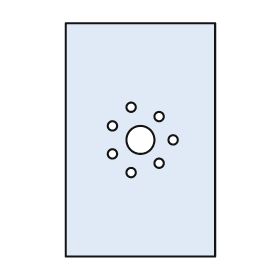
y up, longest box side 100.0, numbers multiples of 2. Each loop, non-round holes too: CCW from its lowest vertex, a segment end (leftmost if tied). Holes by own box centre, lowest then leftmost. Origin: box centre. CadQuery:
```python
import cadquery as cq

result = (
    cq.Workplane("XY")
    .moveTo(-32.0, -50.0)
    .lineTo(32.0, -50.0)
    .lineTo(32.0, 50.0)
    .lineTo(-32.0, 50.0)
    .close()
    .moveTo(-4.0, -14.0)
    .circle(2.0)
    .moveTo(8.0, -10.0)
    .circle(2.0)
    .moveTo(-12.0, -6.0)
    .circle(2.0)
    .moveTo(0.0, 0.0)
    .circle(6.0)
    .moveTo(14.0, 0.0)
    .circle(2.0)
    .moveTo(-12.0, 6.0)
    .circle(2.0)
    .moveTo(8.0, 10.0)
    .circle(2.0)
    .moveTo(-4.0, 14.0)
    .circle(2.0)
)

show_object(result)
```